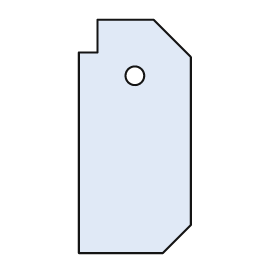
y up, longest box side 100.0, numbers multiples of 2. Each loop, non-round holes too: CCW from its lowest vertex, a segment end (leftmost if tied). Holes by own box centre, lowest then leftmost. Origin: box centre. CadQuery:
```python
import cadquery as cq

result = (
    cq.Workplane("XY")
    .moveTo(-24.0, -50.0)
    .lineTo(12.0, -50.0)
    .lineTo(24.0, -38.0)
    .lineTo(24.0, 34.0)
    .lineTo(8.0, 50.0)
    .lineTo(-16.0, 50.0)
    .lineTo(-16.0, 36.0)
    .lineTo(-24.0, 36.0)
    .close()
    .moveTo(0.0, 26.0)
    .circle(4.0)
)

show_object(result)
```